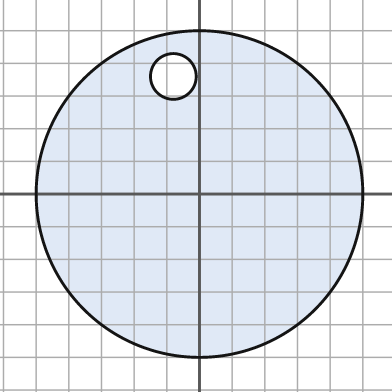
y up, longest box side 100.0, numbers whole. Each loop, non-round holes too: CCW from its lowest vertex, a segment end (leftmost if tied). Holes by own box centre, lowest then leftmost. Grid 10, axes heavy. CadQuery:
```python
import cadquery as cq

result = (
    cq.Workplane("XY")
    .moveTo(0.0, 0.0)
    .circle(50.0)
    .moveTo(-8.0, 36.0)
    .circle(7.0)
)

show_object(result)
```